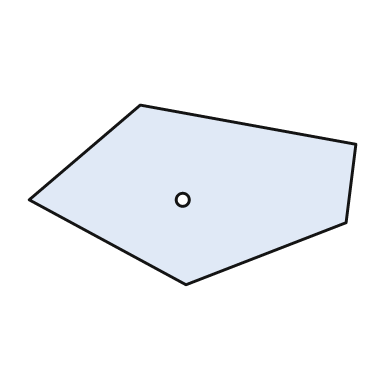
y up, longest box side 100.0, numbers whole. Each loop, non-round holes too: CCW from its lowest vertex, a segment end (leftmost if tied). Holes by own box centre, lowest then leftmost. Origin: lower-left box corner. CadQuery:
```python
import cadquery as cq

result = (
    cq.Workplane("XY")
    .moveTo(48.0, 0.0)
    .lineTo(97.0, 19.0)
    .lineTo(100.0, 43.0)
    .lineTo(34.0, 55.0)
    .lineTo(0.0, 26.0)
    .close()
    .moveTo(47.0, 26.0)
    .circle(2.0)
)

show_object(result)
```